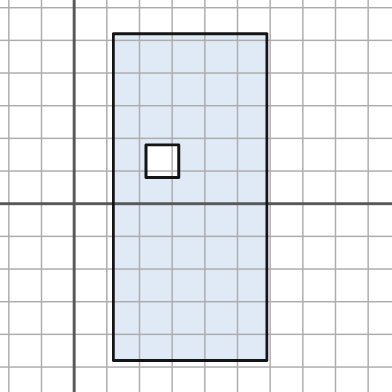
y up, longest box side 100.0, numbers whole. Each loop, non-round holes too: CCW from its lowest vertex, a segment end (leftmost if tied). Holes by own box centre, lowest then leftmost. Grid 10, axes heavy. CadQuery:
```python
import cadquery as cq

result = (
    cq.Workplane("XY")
    .moveTo(12.0, -48.0)
    .lineTo(59.0, -48.0)
    .lineTo(59.0, 52.0)
    .lineTo(12.0, 52.0)
    .close()
    .moveTo(22.0, 8.0)
    .lineTo(32.0, 8.0)
    .lineTo(32.0, 18.0)
    .lineTo(22.0, 18.0)
    .close()
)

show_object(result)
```